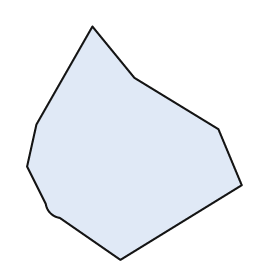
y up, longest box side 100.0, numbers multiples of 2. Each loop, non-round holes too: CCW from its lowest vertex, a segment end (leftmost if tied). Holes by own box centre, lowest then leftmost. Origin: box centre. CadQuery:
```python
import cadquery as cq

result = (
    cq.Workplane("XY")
    .moveTo(-6.0, -50.0)
    .lineTo(46.0, -18.0)
    .lineTo(36.0, 6.0)
    .lineTo(0.0, 28.0)
    .lineTo(-18.0, 50.0)
    .lineTo(-42.0, 8.0)
    .lineTo(-46.0, -10.0)
    .lineTo(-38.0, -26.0)
    .threePointArc((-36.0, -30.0), (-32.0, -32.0))
    .close()
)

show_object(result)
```